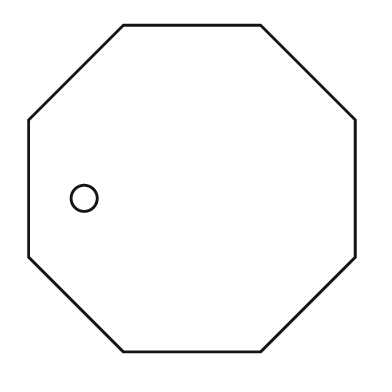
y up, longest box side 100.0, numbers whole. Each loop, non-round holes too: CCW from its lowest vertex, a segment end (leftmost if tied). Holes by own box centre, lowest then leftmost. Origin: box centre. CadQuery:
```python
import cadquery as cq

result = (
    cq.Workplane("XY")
    .moveTo(-21.0, -50.0)
    .lineTo(21.0, -50.0)
    .lineTo(50.0, -21.0)
    .lineTo(50.0, 21.0)
    .lineTo(21.0, 50.0)
    .lineTo(-21.0, 50.0)
    .lineTo(-50.0, 21.0)
    .lineTo(-50.0, -21.0)
    .close()
    .moveTo(-33.0, -3.0)
    .circle(4.0)
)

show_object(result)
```